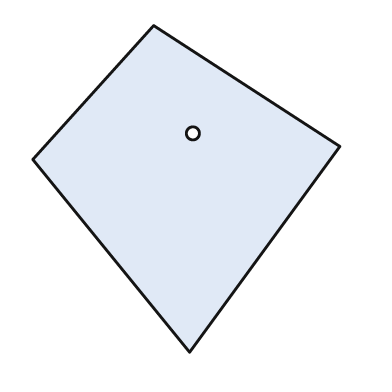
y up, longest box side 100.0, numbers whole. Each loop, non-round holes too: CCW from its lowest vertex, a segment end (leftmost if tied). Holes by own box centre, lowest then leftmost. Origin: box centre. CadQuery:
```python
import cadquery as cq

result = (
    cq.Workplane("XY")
    .moveTo(1.0, -50.0)
    .lineTo(47.0, 13.0)
    .lineTo(-10.0, 50.0)
    .lineTo(-47.0, 9.0)
    .close()
    .moveTo(2.0, 17.0)
    .circle(2.0)
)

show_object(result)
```